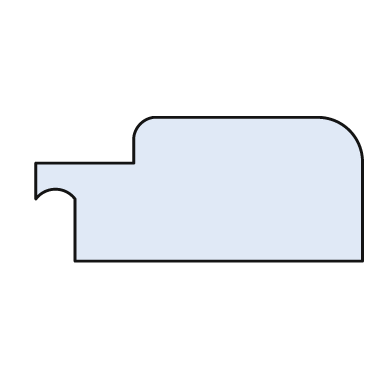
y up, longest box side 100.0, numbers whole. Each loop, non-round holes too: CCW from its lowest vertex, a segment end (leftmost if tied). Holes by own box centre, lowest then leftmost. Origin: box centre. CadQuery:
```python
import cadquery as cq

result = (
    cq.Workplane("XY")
    .moveTo(-38.0, -22.0)
    .lineTo(50.0, -22.0)
    .lineTo(50.0, 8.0)
    .threePointArc((46.0, 18.0), (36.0, 22.0))
    .lineTo(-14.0, 22.0)
    .threePointArc((-18.0, 20.0), (-20.0, 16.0))
    .lineTo(-20.0, 8.0)
    .lineTo(-50.0, 8.0)
    .lineTo(-50.0, -3.0)
    .threePointArc((-44.0, 0.0), (-38.0, -3.0))
    .close()
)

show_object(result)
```